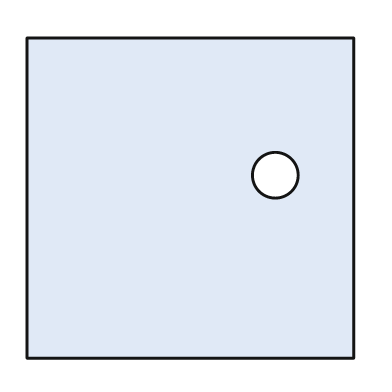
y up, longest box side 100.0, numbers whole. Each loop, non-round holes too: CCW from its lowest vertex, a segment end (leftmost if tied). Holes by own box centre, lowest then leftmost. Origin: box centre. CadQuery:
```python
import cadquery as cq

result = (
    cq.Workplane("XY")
    .moveTo(-50.0, -49.0)
    .lineTo(50.0, -49.0)
    .lineTo(50.0, 49.0)
    .lineTo(-50.0, 49.0)
    .close()
    .moveTo(26.0, 7.0)
    .circle(7.0)
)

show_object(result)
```